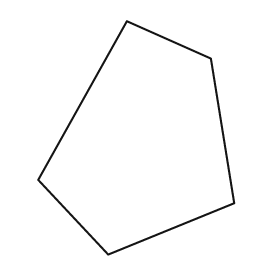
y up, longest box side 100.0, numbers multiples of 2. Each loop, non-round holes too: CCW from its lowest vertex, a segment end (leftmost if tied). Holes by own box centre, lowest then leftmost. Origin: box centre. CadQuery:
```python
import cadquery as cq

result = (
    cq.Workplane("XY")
    .moveTo(-12.0, -50.0)
    .lineTo(42.0, -28.0)
    .lineTo(32.0, 34.0)
    .lineTo(-4.0, 50.0)
    .lineTo(-42.0, -18.0)
    .close()
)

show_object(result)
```